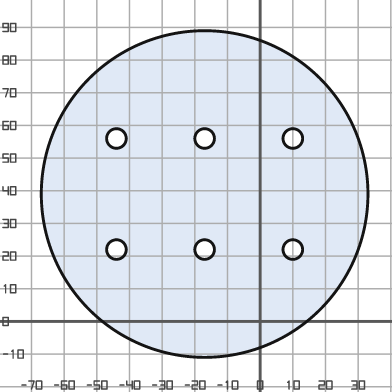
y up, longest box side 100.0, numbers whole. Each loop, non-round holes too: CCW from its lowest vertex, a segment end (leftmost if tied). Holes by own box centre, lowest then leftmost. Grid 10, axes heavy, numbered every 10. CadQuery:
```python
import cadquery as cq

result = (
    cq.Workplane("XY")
    .moveTo(-17.0, 39.0)
    .circle(50.0)
    .moveTo(-44.0, 22.0)
    .circle(3.0)
    .moveTo(-17.0, 22.0)
    .circle(3.0)
    .moveTo(10.0, 22.0)
    .circle(3.0)
    .moveTo(-44.0, 56.0)
    .circle(3.0)
    .moveTo(-17.0, 56.0)
    .circle(3.0)
    .moveTo(10.0, 56.0)
    .circle(3.0)
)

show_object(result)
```